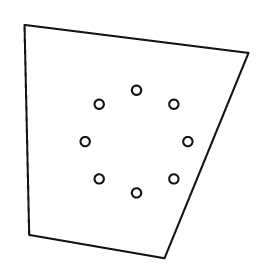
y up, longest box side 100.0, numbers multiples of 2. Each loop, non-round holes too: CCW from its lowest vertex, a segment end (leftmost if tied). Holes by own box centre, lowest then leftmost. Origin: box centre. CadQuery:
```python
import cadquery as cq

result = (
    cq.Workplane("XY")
    .moveTo(12.0, -50.0)
    .lineTo(48.0, 38.0)
    .lineTo(-48.0, 50.0)
    .lineTo(-46.0, -40.0)
    .close()
    .moveTo(0.0, -22.0)
    .circle(2.0)
    .moveTo(-16.0, -16.0)
    .circle(2.0)
    .moveTo(16.0, -16.0)
    .circle(2.0)
    .moveTo(-22.0, 0.0)
    .circle(2.0)
    .moveTo(22.0, 0.0)
    .circle(2.0)
    .moveTo(-16.0, 16.0)
    .circle(2.0)
    .moveTo(16.0, 16.0)
    .circle(2.0)
    .moveTo(0.0, 22.0)
    .circle(2.0)
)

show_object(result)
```